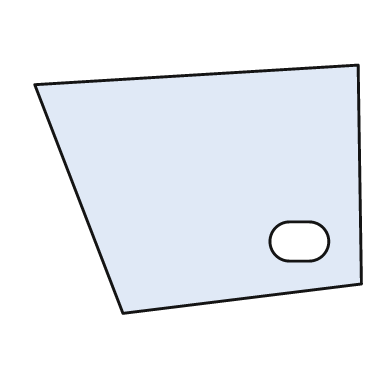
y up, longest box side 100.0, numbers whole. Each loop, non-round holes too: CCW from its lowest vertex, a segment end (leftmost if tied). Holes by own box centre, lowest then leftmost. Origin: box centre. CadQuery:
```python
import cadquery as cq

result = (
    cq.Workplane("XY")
    .moveTo(-23.0, -38.0)
    .lineTo(50.0, -29.0)
    .lineTo(49.0, 38.0)
    .lineTo(-50.0, 32.0)
    .close()
    .moveTo(28.0, -22.0)
    .lineTo(34.0, -22.0)
    .threePointArc((40.0, -16.0), (34.0, -10.0))
    .lineTo(28.0, -10.0)
    .threePointArc((22.0, -16.0), (28.0, -22.0))
    .close()
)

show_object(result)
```